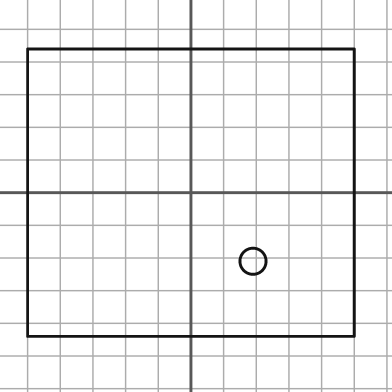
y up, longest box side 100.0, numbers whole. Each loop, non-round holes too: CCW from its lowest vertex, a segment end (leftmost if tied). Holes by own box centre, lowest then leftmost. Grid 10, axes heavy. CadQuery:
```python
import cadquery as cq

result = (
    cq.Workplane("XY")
    .moveTo(-50.0, -44.0)
    .lineTo(50.0, -44.0)
    .lineTo(50.0, 44.0)
    .lineTo(-50.0, 44.0)
    .close()
    .moveTo(19.0, -21.0)
    .circle(4.0)
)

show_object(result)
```